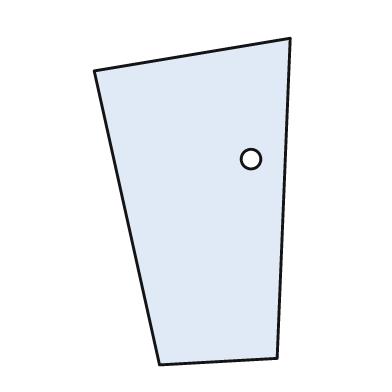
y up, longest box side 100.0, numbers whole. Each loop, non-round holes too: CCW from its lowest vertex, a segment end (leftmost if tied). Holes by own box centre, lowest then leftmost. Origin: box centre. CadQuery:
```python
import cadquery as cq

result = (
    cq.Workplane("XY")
    .moveTo(-10.0, -50.0)
    .lineTo(26.0, -48.0)
    .lineTo(30.0, 50.0)
    .lineTo(-30.0, 40.0)
    .close()
    .moveTo(18.0, 13.0)
    .circle(3.0)
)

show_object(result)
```